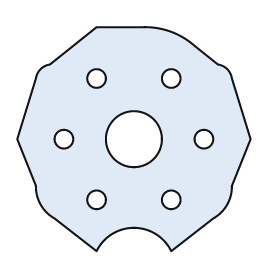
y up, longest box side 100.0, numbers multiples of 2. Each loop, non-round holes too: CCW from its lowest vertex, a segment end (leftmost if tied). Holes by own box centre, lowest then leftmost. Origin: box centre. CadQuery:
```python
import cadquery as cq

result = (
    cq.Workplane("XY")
    .moveTo(-16.0, -48.0)
    .threePointArc((0.0, -38.0), (16.0, -48.0))
    .lineTo(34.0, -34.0)
    .threePointArc((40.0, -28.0), (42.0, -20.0))
    .lineTo(50.0, 0.0)
    .lineTo(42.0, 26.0)
    .threePointArc((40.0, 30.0), (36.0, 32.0))
    .lineTo(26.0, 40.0)
    .threePointArc((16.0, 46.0), (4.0, 48.0))
    .lineTo(-16.0, 48.0)
    .lineTo(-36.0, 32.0)
    .threePointArc((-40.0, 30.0), (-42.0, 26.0))
    .lineTo(-50.0, 0.0)
    .lineTo(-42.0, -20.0)
    .threePointArc((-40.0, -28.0), (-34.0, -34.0))
    .close()
    .moveTo(-16.0, -26.0)
    .circle(4.0)
    .moveTo(16.0, -26.0)
    .circle(4.0)
    .moveTo(-30.0, 0.0)
    .circle(4.0)
    .moveTo(0.0, 0.0)
    .circle(12.0)
    .moveTo(30.0, 0.0)
    .circle(4.0)
    .moveTo(-16.0, 26.0)
    .circle(4.0)
    .moveTo(16.0, 26.0)
    .circle(4.0)
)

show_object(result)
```